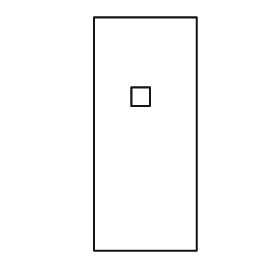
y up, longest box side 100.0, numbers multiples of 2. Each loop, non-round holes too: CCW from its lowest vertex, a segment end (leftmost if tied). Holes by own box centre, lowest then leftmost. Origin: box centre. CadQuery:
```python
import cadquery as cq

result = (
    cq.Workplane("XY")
    .moveTo(-22.0, -50.0)
    .lineTo(22.0, -50.0)
    .lineTo(22.0, 50.0)
    .lineTo(-22.0, 50.0)
    .close()
    .moveTo(-6.0, 12.0)
    .lineTo(2.0, 12.0)
    .lineTo(2.0, 20.0)
    .lineTo(-6.0, 20.0)
    .close()
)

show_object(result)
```